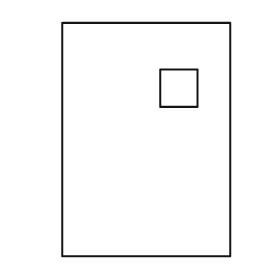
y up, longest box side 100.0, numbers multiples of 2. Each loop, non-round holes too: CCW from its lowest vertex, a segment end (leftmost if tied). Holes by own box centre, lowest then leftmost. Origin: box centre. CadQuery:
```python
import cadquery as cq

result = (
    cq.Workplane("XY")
    .moveTo(-36.0, -50.0)
    .lineTo(36.0, -50.0)
    .lineTo(36.0, 50.0)
    .lineTo(-36.0, 50.0)
    .close()
    .moveTo(6.0, 14.0)
    .lineTo(22.0, 14.0)
    .lineTo(22.0, 30.0)
    .lineTo(6.0, 30.0)
    .close()
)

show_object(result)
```